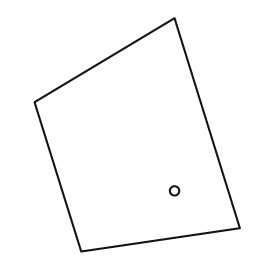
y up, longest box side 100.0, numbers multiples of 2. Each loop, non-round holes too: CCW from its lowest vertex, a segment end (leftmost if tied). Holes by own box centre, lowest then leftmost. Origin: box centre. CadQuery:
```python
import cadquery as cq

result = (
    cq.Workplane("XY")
    .moveTo(-24.0, -50.0)
    .lineTo(44.0, -40.0)
    .lineTo(16.0, 50.0)
    .lineTo(-44.0, 14.0)
    .close()
    .moveTo(16.0, -24.0)
    .circle(2.0)
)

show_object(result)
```